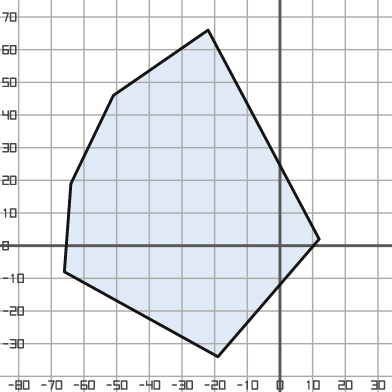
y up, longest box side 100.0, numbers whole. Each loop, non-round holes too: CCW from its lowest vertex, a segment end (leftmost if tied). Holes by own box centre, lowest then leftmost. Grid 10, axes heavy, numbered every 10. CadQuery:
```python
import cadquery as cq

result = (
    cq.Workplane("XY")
    .moveTo(-19.0, -34.0)
    .lineTo(12.0, 2.0)
    .lineTo(-22.0, 66.0)
    .lineTo(-51.0, 46.0)
    .lineTo(-64.0, 19.0)
    .lineTo(-66.0, -8.0)
    .close()
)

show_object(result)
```